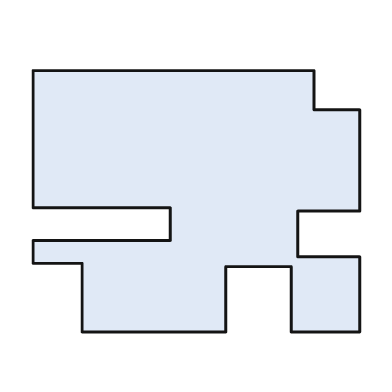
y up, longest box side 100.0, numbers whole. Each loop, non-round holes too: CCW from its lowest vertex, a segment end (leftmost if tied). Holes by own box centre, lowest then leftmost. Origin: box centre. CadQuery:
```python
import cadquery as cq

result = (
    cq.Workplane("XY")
    .moveTo(-35.0, -40.0)
    .lineTo(9.0, -40.0)
    .lineTo(9.0, -20.0)
    .lineTo(29.0, -20.0)
    .lineTo(29.0, -40.0)
    .lineTo(50.0, -40.0)
    .lineTo(50.0, -17.0)
    .lineTo(31.0, -17.0)
    .lineTo(31.0, -3.0)
    .lineTo(50.0, -3.0)
    .lineTo(50.0, 28.0)
    .lineTo(36.0, 28.0)
    .lineTo(36.0, 40.0)
    .lineTo(-50.0, 40.0)
    .lineTo(-50.0, -2.0)
    .lineTo(-8.0, -2.0)
    .lineTo(-8.0, -12.0)
    .lineTo(-50.0, -12.0)
    .lineTo(-50.0, -19.0)
    .lineTo(-35.0, -19.0)
    .close()
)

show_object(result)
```